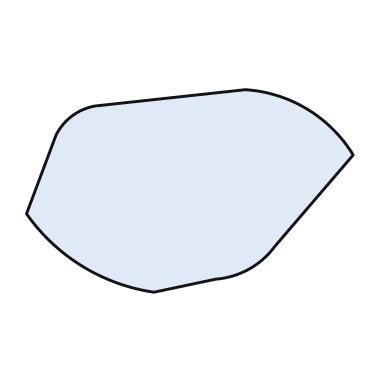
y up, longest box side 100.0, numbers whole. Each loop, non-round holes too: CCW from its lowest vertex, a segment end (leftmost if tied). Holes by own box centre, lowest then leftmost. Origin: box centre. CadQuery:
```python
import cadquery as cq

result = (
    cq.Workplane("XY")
    .moveTo(-11.0, -31.0)
    .lineTo(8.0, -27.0)
    .threePointArc((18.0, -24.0), (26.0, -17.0))
    .lineTo(50.0, 11.0)
    .threePointArc((36.0, 25.0), (17.0, 31.0))
    .lineTo(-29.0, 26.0)
    .threePointArc((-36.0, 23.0), (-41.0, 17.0))
    .lineTo(-50.0, -7.0)
    .threePointArc((-33.0, -23.0), (-11.0, -31.0))
    .close()
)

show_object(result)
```